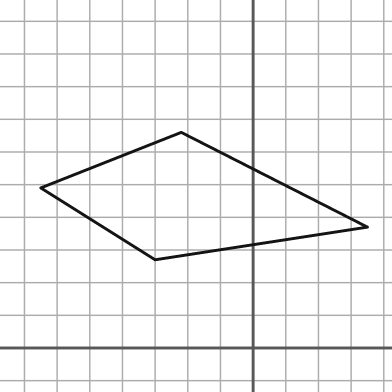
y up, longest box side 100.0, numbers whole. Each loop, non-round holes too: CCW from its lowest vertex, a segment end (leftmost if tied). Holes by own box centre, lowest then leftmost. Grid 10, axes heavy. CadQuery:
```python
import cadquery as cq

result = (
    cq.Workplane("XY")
    .moveTo(-30.0, 27.0)
    .lineTo(35.0, 37.0)
    .lineTo(-22.0, 66.0)
    .lineTo(-65.0, 49.0)
    .close()
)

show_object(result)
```